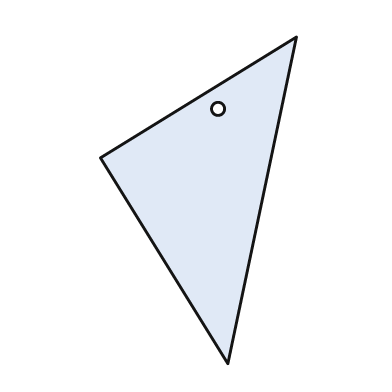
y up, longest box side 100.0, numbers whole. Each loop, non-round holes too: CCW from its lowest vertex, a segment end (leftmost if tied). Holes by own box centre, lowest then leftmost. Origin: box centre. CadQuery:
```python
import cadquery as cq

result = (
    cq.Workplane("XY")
    .moveTo(9.0, -50.0)
    .lineTo(30.0, 50.0)
    .lineTo(-30.0, 13.0)
    .close()
    .moveTo(6.0, 28.0)
    .circle(2.0)
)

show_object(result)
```